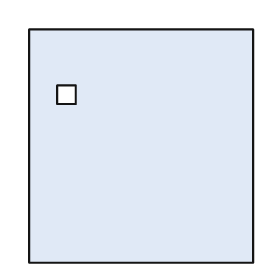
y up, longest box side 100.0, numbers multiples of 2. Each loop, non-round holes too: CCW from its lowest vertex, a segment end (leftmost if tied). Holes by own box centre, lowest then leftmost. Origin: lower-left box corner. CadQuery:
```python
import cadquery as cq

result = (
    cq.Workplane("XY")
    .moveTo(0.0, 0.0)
    .lineTo(96.0, 0.0)
    .lineTo(96.0, 100.0)
    .lineTo(0.0, 100.0)
    .close()
    .moveTo(12.0, 68.0)
    .lineTo(20.0, 68.0)
    .lineTo(20.0, 76.0)
    .lineTo(12.0, 76.0)
    .close()
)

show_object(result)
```